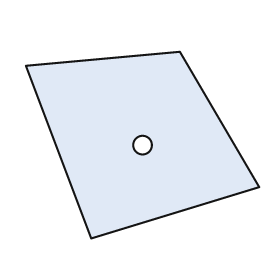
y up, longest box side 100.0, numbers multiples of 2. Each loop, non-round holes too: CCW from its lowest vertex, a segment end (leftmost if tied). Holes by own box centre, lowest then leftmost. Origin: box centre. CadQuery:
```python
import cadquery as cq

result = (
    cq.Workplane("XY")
    .moveTo(-22.0, -40.0)
    .lineTo(50.0, -18.0)
    .lineTo(16.0, 40.0)
    .lineTo(-50.0, 34.0)
    .close()
    .moveTo(0.0, 0.0)
    .circle(4.0)
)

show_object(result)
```